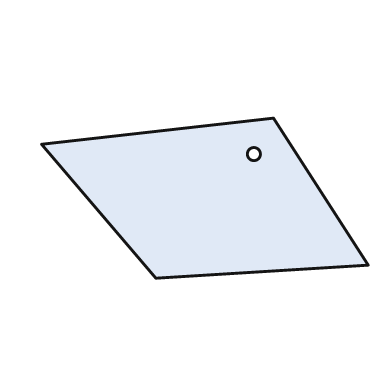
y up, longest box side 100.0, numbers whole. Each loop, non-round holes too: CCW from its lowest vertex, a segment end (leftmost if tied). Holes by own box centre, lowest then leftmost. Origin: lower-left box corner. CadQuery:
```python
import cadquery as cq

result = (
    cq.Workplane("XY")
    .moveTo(35.0, 0.0)
    .lineTo(100.0, 4.0)
    .lineTo(71.0, 49.0)
    .lineTo(0.0, 41.0)
    .close()
    .moveTo(65.0, 38.0)
    .circle(2.0)
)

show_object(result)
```